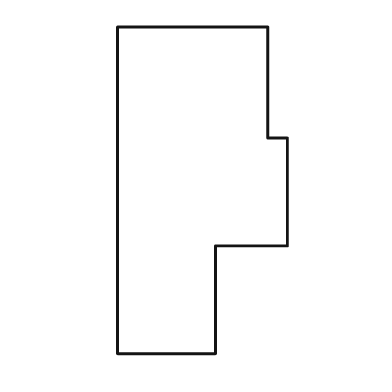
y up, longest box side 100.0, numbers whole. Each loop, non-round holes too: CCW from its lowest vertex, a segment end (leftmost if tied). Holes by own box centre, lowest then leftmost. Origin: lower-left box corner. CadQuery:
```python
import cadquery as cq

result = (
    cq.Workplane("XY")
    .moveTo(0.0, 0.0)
    .lineTo(30.0, 0.0)
    .lineTo(30.0, 33.0)
    .lineTo(52.0, 33.0)
    .lineTo(52.0, 66.0)
    .lineTo(46.0, 66.0)
    .lineTo(46.0, 100.0)
    .lineTo(0.0, 100.0)
    .close()
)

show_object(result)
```